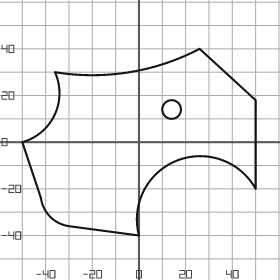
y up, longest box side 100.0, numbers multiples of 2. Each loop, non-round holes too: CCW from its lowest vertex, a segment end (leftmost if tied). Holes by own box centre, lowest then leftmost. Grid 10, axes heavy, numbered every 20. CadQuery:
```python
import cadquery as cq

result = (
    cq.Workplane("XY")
    .moveTo(0.0, -40.0)
    .threePointArc((16.0, -8.0), (50.0, -20.0))
    .lineTo(50.0, 18.0)
    .lineTo(26.0, 40.0)
    .threePointArc((-4.0, 30.0), (-36.0, 30.0))
    .threePointArc((-36.0, 12.0), (-50.0, 0.0))
    .lineTo(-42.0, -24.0)
    .threePointArc((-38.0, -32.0), (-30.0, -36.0))
    .close()
    .moveTo(14.0, 14.0)
    .circle(4.0)
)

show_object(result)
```